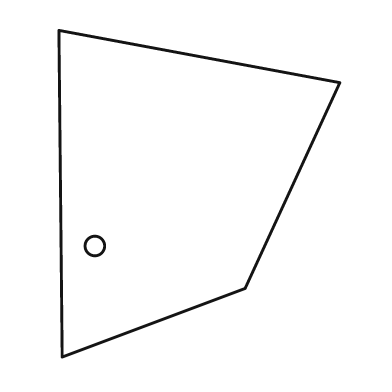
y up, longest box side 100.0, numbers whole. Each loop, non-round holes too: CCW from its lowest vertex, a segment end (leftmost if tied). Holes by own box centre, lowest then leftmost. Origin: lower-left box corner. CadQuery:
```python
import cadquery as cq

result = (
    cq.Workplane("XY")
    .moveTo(1.0, 0.0)
    .lineTo(57.0, 21.0)
    .lineTo(86.0, 84.0)
    .lineTo(0.0, 100.0)
    .close()
    .moveTo(11.0, 34.0)
    .circle(3.0)
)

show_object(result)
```